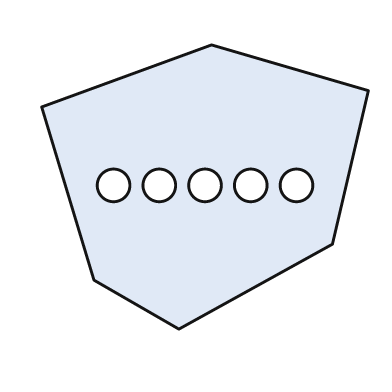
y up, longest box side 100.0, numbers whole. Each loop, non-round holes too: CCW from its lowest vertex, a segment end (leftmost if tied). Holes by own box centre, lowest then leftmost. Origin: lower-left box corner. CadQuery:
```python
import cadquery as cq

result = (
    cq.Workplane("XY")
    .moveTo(42.0, 0.0)
    .lineTo(89.0, 26.0)
    .lineTo(100.0, 73.0)
    .lineTo(52.0, 87.0)
    .lineTo(0.0, 68.0)
    .lineTo(16.0, 15.0)
    .close()
    .moveTo(22.0, 44.0)
    .circle(5.0)
    .moveTo(36.0, 44.0)
    .circle(5.0)
    .moveTo(50.0, 44.0)
    .circle(5.0)
    .moveTo(64.0, 44.0)
    .circle(5.0)
    .moveTo(78.0, 44.0)
    .circle(5.0)
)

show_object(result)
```